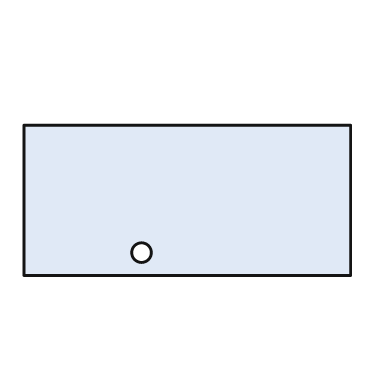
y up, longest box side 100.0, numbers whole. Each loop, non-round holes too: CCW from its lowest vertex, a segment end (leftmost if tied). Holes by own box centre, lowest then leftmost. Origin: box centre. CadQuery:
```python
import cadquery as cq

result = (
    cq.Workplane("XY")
    .moveTo(-50.0, -23.0)
    .lineTo(50.0, -23.0)
    .lineTo(50.0, 23.0)
    .lineTo(-50.0, 23.0)
    .close()
    .moveTo(-14.0, -16.0)
    .circle(3.0)
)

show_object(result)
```